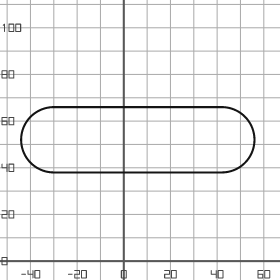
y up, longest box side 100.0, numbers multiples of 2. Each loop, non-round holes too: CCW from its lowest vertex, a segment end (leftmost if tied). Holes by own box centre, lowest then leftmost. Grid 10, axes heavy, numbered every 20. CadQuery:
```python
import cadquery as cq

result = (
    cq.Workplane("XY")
    .moveTo(-30.0, 38.0)
    .lineTo(42.0, 38.0)
    .threePointArc((56.0, 52.0), (42.0, 66.0))
    .lineTo(-30.0, 66.0)
    .threePointArc((-44.0, 52.0), (-30.0, 38.0))
    .close()
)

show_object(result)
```